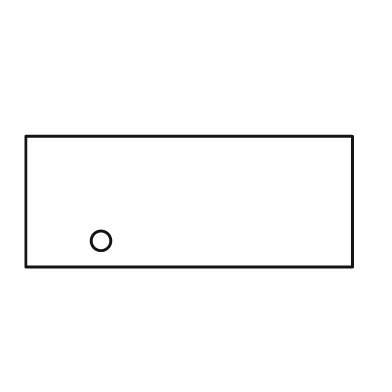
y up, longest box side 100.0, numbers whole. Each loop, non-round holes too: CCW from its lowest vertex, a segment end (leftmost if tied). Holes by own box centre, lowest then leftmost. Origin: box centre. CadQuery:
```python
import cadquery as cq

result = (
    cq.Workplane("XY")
    .moveTo(-50.0, -20.0)
    .lineTo(50.0, -20.0)
    .lineTo(50.0, 20.0)
    .lineTo(-50.0, 20.0)
    .close()
    .moveTo(-27.0, -12.0)
    .circle(3.0)
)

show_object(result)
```